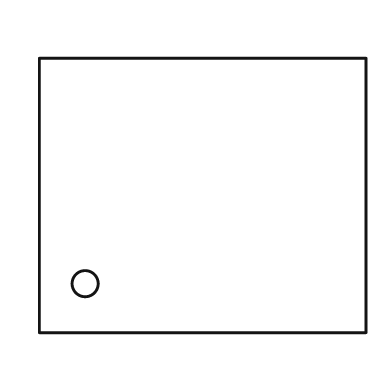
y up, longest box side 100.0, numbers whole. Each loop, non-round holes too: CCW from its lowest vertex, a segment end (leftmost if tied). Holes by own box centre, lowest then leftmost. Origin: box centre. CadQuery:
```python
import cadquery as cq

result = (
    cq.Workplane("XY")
    .moveTo(-50.0, -42.0)
    .lineTo(50.0, -42.0)
    .lineTo(50.0, 42.0)
    .lineTo(-50.0, 42.0)
    .close()
    .moveTo(-36.0, -27.0)
    .circle(4.0)
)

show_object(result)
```